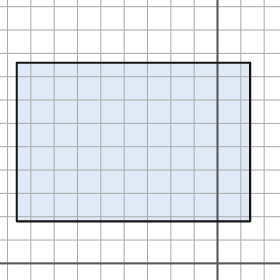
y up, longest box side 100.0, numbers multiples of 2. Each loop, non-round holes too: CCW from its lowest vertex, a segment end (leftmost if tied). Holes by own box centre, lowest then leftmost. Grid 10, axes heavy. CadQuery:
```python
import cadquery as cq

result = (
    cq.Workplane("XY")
    .moveTo(-86.0, 18.0)
    .lineTo(14.0, 18.0)
    .lineTo(14.0, 86.0)
    .lineTo(-86.0, 86.0)
    .close()
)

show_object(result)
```